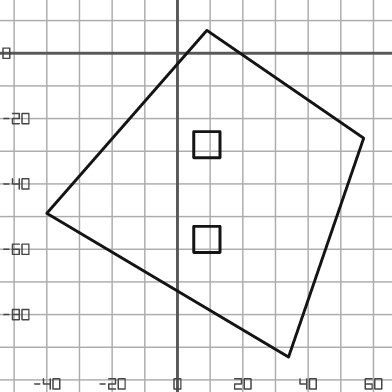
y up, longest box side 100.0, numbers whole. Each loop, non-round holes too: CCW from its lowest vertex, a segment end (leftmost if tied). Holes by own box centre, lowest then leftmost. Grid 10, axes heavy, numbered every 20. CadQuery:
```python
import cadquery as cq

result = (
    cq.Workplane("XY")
    .moveTo(34.0, -93.0)
    .lineTo(57.0, -26.0)
    .lineTo(9.0, 7.0)
    .lineTo(-40.0, -49.0)
    .close()
    .moveTo(5.0, -61.0)
    .lineTo(13.0, -61.0)
    .lineTo(13.0, -53.0)
    .lineTo(5.0, -53.0)
    .close()
    .moveTo(5.0, -32.0)
    .lineTo(13.0, -32.0)
    .lineTo(13.0, -24.0)
    .lineTo(5.0, -24.0)
    .close()
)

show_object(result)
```